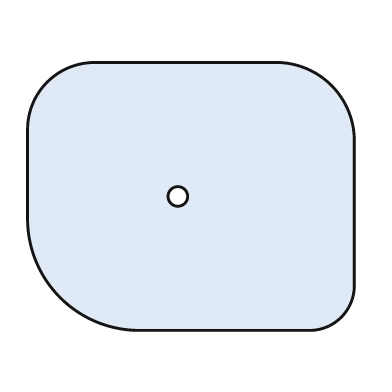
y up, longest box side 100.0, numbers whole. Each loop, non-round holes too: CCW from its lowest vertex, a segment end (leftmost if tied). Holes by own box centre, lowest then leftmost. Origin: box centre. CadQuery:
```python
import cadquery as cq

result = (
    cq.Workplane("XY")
    .moveTo(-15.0, -41.0)
    .lineTo(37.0, -41.0)
    .threePointArc((46.0, -37.0), (50.0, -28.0))
    .lineTo(50.0, 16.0)
    .threePointArc((43.0, 34.0), (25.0, 41.0))
    .lineTo(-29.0, 41.0)
    .threePointArc((-44.0, 35.0), (-50.0, 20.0))
    .lineTo(-50.0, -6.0)
    .threePointArc((-40.0, -31.0), (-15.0, -41.0))
    .close()
    .moveTo(-4.0, 0.0)
    .circle(3.0)
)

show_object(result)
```